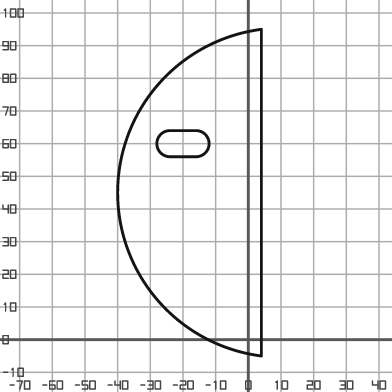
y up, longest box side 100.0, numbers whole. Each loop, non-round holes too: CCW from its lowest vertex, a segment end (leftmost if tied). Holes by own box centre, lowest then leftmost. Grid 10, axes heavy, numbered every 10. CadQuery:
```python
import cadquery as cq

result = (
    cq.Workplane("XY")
    .moveTo(4.0, -5.0)
    .lineTo(4.0, 95.0)
    .threePointArc((-40.0, 45.0), (4.0, -5.0))
    .close()
    .moveTo(-24.0, 56.0)
    .lineTo(-16.0, 56.0)
    .threePointArc((-12.0, 60.0), (-16.0, 64.0))
    .lineTo(-24.0, 64.0)
    .threePointArc((-28.0, 60.0), (-24.0, 56.0))
    .close()
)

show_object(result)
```